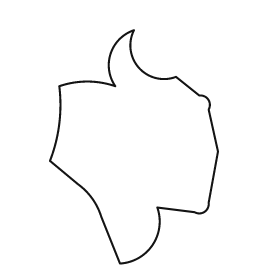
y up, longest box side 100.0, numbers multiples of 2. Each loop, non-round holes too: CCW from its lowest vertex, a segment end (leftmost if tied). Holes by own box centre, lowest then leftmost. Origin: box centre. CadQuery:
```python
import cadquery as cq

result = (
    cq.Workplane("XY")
    .moveTo(-6.0, -50.0)
    .threePointArc((8.0, -42.0), (10.0, -26.0))
    .lineTo(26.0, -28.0)
    .threePointArc((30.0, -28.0), (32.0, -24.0))
    .lineTo(36.0, -2.0)
    .lineTo(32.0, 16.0)
    .threePointArc((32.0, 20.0), (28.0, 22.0))
    .lineTo(18.0, 30.0)
    .threePointArc((2.0, 34.0), (0.0, 50.0))
    .threePointArc((-10.0, 40.0), (-8.0, 26.0))
    .threePointArc((-20.0, 28.0), (-32.0, 26.0))
    .threePointArc((-32.0, 10.0), (-36.0, -6.0))
    .lineTo(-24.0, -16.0)
    .threePointArc((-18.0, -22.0), (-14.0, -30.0))
    .close()
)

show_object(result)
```